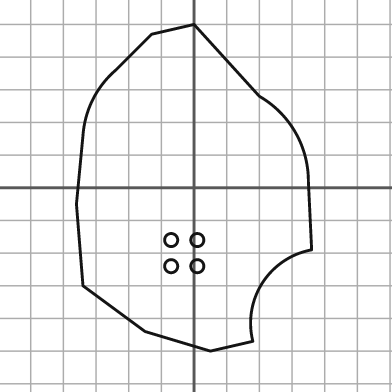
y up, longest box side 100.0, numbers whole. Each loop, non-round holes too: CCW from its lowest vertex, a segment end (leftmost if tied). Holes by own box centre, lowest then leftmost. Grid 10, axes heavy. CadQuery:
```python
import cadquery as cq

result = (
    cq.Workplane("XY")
    .moveTo(5.0, -50.0)
    .lineTo(18.0, -47.0)
    .threePointArc((21.0, -29.0), (36.0, -19.0))
    .lineTo(35.0, 2.0)
    .threePointArc((31.0, 17.0), (20.0, 28.0))
    .lineTo(0.0, 50.0)
    .lineTo(-13.0, 47.0)
    .lineTo(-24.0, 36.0)
    .threePointArc((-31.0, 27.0), (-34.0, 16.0))
    .lineTo(-36.0, -5.0)
    .lineTo(-34.0, -30.0)
    .lineTo(-15.0, -44.0)
    .close()
    .moveTo(-7.0, -24.0)
    .circle(2.0)
    .moveTo(1.0, -24.0)
    .circle(2.0)
    .moveTo(-7.0, -16.0)
    .circle(2.0)
    .moveTo(1.0, -16.0)
    .circle(2.0)
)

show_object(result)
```